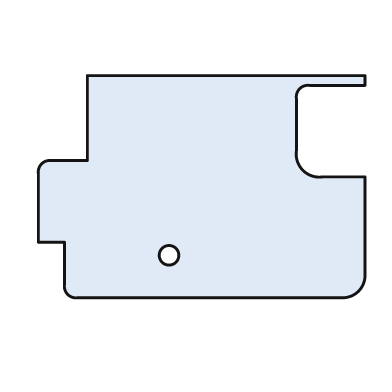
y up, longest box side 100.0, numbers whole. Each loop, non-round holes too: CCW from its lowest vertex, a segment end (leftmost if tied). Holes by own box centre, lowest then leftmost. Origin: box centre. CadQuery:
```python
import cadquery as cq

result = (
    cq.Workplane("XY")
    .moveTo(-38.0, -34.0)
    .lineTo(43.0, -34.0)
    .threePointArc((48.0, -32.0), (50.0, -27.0))
    .lineTo(50.0, 3.0)
    .lineTo(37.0, 3.0)
    .threePointArc((31.0, 5.0), (29.0, 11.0))
    .lineTo(29.0, 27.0)
    .threePointArc((30.0, 30.0), (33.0, 31.0))
    .lineTo(50.0, 31.0)
    .lineTo(50.0, 34.0)
    .lineTo(-35.0, 34.0)
    .lineTo(-35.0, 8.0)
    .lineTo(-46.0, 8.0)
    .threePointArc((-49.0, 7.0), (-50.0, 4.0))
    .lineTo(-50.0, -17.0)
    .lineTo(-42.0, -17.0)
    .lineTo(-42.0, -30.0)
    .threePointArc((-41.0, -33.0), (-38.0, -34.0))
    .close()
    .moveTo(-10.0, -21.0)
    .circle(3.0)
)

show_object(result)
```